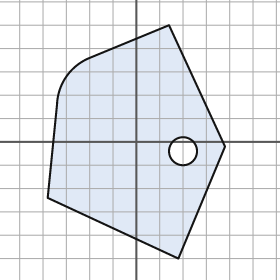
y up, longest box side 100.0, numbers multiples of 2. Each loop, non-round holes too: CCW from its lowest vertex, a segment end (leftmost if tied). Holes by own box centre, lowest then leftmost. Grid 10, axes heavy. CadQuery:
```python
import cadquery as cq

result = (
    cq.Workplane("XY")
    .moveTo(18.0, -50.0)
    .lineTo(38.0, -2.0)
    .lineTo(14.0, 50.0)
    .lineTo(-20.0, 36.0)
    .threePointArc((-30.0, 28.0), (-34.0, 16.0))
    .lineTo(-38.0, -24.0)
    .close()
    .moveTo(20.0, -4.0)
    .circle(6.0)
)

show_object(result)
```